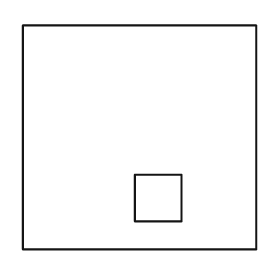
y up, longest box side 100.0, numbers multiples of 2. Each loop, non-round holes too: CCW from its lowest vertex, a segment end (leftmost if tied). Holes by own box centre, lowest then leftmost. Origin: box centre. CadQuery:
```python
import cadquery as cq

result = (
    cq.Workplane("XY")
    .moveTo(-50.0, -48.0)
    .lineTo(50.0, -48.0)
    .lineTo(50.0, 48.0)
    .lineTo(-50.0, 48.0)
    .close()
    .moveTo(-2.0, -36.0)
    .lineTo(18.0, -36.0)
    .lineTo(18.0, -16.0)
    .lineTo(-2.0, -16.0)
    .close()
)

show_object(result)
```